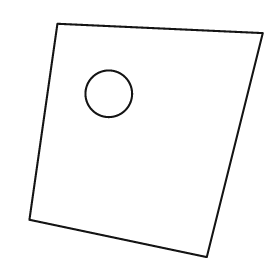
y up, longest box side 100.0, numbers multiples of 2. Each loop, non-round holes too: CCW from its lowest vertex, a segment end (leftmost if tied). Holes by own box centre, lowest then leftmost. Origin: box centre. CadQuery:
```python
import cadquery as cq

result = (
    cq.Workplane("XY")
    .moveTo(26.0, -50.0)
    .lineTo(50.0, 46.0)
    .lineTo(-38.0, 50.0)
    .lineTo(-50.0, -34.0)
    .close()
    .moveTo(-16.0, 20.0)
    .circle(10.0)
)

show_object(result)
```